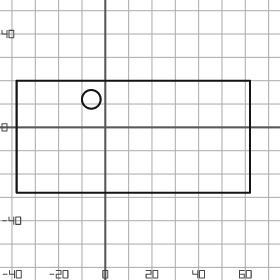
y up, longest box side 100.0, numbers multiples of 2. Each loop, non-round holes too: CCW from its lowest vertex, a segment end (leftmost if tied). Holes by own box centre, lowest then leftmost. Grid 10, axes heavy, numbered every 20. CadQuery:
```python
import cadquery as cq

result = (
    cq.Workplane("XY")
    .moveTo(-38.0, -28.0)
    .lineTo(62.0, -28.0)
    .lineTo(62.0, 20.0)
    .lineTo(-38.0, 20.0)
    .close()
    .moveTo(-6.0, 12.0)
    .circle(4.0)
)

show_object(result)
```